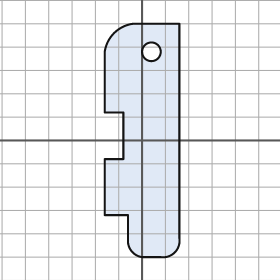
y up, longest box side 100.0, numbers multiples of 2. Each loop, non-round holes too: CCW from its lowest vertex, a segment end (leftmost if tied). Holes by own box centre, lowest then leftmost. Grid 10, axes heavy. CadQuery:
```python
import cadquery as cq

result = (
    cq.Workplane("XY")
    .moveTo(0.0, -50.0)
    .lineTo(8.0, -50.0)
    .threePointArc((14.0, -48.0), (16.0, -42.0))
    .lineTo(16.0, 50.0)
    .lineTo(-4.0, 50.0)
    .threePointArc((-12.0, 46.0), (-16.0, 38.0))
    .lineTo(-16.0, 12.0)
    .lineTo(-8.0, 12.0)
    .lineTo(-8.0, -8.0)
    .lineTo(-16.0, -8.0)
    .lineTo(-16.0, -32.0)
    .lineTo(-6.0, -32.0)
    .lineTo(-6.0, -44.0)
    .threePointArc((-4.0, -48.0), (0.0, -50.0))
    .close()
    .moveTo(4.0, 38.0)
    .circle(4.0)
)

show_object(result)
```